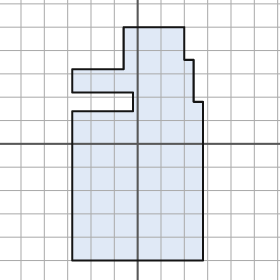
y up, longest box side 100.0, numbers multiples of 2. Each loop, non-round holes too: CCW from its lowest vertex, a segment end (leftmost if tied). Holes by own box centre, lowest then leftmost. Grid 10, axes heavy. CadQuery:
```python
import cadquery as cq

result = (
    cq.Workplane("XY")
    .moveTo(-28.0, -50.0)
    .lineTo(28.0, -50.0)
    .lineTo(28.0, 18.0)
    .lineTo(24.0, 18.0)
    .lineTo(24.0, 36.0)
    .lineTo(20.0, 36.0)
    .lineTo(20.0, 50.0)
    .lineTo(-6.0, 50.0)
    .lineTo(-6.0, 32.0)
    .lineTo(-28.0, 32.0)
    .lineTo(-28.0, 22.0)
    .lineTo(-2.0, 22.0)
    .lineTo(-2.0, 14.0)
    .lineTo(-28.0, 14.0)
    .close()
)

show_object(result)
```